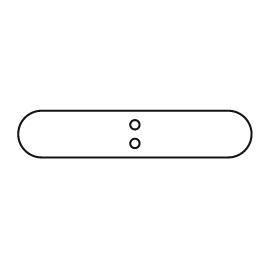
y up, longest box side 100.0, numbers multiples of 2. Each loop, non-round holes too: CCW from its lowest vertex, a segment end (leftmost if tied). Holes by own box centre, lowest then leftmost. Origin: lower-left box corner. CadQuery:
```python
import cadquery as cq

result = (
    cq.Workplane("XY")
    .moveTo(10.0, 0.0)
    .lineTo(90.0, 0.0)
    .threePointArc((100.0, 10.0), (90.0, 20.0))
    .lineTo(10.0, 20.0)
    .threePointArc((0.0, 10.0), (10.0, 0.0))
    .close()
    .moveTo(50.0, 6.0)
    .circle(2.0)
    .moveTo(50.0, 14.0)
    .circle(2.0)
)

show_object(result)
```